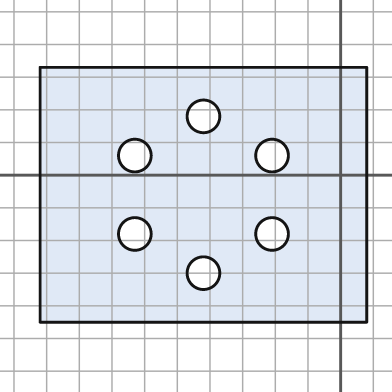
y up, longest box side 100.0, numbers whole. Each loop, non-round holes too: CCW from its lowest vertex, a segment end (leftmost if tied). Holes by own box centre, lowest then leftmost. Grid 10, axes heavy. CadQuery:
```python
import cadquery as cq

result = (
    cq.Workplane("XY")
    .moveTo(-92.0, -45.0)
    .lineTo(8.0, -45.0)
    .lineTo(8.0, 33.0)
    .lineTo(-92.0, 33.0)
    .close()
    .moveTo(-42.0, -30.0)
    .circle(5.0)
    .moveTo(-63.0, -18.0)
    .circle(5.0)
    .moveTo(-21.0, -18.0)
    .circle(5.0)
    .moveTo(-63.0, 6.0)
    .circle(5.0)
    .moveTo(-21.0, 6.0)
    .circle(5.0)
    .moveTo(-42.0, 18.0)
    .circle(5.0)
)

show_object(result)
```